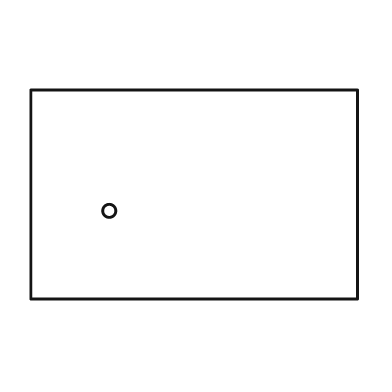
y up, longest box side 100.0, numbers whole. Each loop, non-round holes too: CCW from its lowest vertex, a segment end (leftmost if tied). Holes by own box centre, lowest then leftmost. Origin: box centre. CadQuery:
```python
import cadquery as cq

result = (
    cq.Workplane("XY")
    .moveTo(-50.0, -32.0)
    .lineTo(50.0, -32.0)
    .lineTo(50.0, 32.0)
    .lineTo(-50.0, 32.0)
    .close()
    .moveTo(-26.0, -5.0)
    .circle(2.0)
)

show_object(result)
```